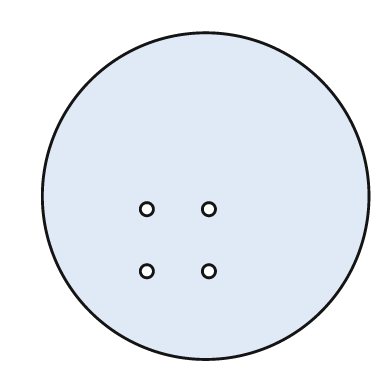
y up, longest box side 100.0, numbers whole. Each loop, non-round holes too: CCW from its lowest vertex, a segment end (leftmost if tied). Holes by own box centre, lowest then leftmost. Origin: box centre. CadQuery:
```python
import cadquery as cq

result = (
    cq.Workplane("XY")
    .moveTo(0.0, 0.0)
    .circle(50.0)
    .moveTo(-18.0, -23.0)
    .circle(2.0)
    .moveTo(1.0, -23.0)
    .circle(2.0)
    .moveTo(-18.0, -4.0)
    .circle(2.0)
    .moveTo(1.0, -4.0)
    .circle(2.0)
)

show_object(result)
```